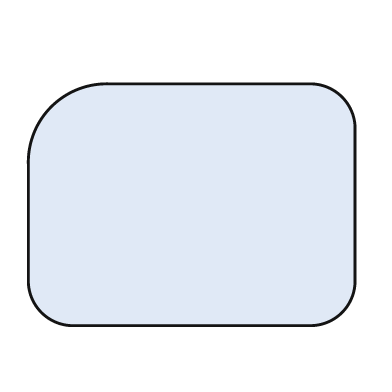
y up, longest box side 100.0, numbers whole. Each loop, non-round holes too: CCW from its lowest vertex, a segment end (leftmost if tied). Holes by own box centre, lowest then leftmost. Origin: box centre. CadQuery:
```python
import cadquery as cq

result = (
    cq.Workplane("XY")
    .moveTo(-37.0, -37.0)
    .lineTo(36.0, -37.0)
    .threePointArc((46.0, -33.0), (50.0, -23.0))
    .lineTo(50.0, 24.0)
    .threePointArc((46.0, 33.0), (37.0, 37.0))
    .lineTo(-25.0, 37.0)
    .threePointArc((-43.0, 30.0), (-50.0, 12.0))
    .lineTo(-50.0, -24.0)
    .threePointArc((-46.0, -33.0), (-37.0, -37.0))
    .close()
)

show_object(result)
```